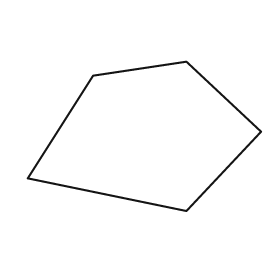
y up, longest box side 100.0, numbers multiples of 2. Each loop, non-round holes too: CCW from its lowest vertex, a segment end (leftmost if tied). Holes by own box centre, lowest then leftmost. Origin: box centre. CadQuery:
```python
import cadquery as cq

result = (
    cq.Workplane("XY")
    .moveTo(18.0, -32.0)
    .lineTo(50.0, 2.0)
    .lineTo(18.0, 32.0)
    .lineTo(-22.0, 26.0)
    .lineTo(-50.0, -18.0)
    .close()
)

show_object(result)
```